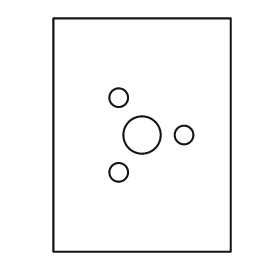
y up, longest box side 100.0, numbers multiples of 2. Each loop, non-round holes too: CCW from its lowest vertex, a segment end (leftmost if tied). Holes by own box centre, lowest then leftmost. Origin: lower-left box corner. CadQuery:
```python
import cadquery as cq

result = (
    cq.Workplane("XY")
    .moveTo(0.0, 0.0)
    .lineTo(76.0, 0.0)
    .lineTo(76.0, 100.0)
    .lineTo(0.0, 100.0)
    .close()
    .moveTo(28.0, 34.0)
    .circle(4.0)
    .moveTo(38.0, 50.0)
    .circle(8.0)
    .moveTo(56.0, 50.0)
    .circle(4.0)
    .moveTo(28.0, 66.0)
    .circle(4.0)
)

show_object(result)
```